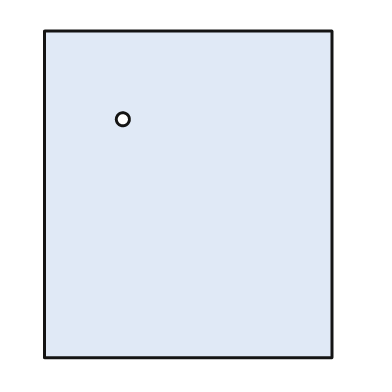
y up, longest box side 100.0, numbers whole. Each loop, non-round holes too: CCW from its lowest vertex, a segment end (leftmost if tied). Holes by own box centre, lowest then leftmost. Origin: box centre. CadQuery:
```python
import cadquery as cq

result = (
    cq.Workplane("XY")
    .moveTo(-44.0, -50.0)
    .lineTo(44.0, -50.0)
    .lineTo(44.0, 50.0)
    .lineTo(-44.0, 50.0)
    .close()
    .moveTo(-20.0, 23.0)
    .circle(2.0)
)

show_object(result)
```